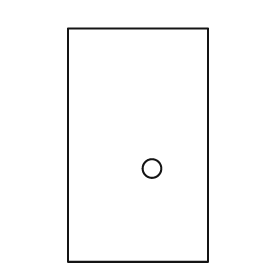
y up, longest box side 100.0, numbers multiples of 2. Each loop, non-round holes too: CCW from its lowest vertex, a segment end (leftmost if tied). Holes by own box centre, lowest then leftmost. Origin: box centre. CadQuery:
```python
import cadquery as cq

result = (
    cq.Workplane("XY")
    .moveTo(-30.0, -50.0)
    .lineTo(30.0, -50.0)
    .lineTo(30.0, 50.0)
    .lineTo(-30.0, 50.0)
    .close()
    .moveTo(6.0, -10.0)
    .circle(4.0)
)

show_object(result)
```